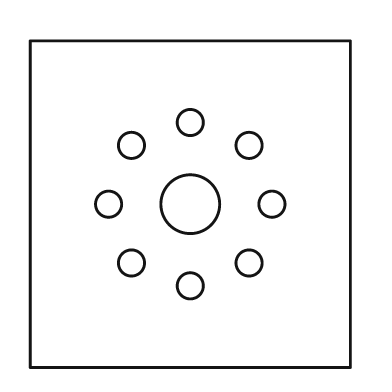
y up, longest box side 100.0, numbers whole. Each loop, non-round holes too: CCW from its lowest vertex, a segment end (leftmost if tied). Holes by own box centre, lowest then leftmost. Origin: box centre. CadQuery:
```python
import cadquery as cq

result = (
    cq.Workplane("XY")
    .moveTo(-49.0, -50.0)
    .lineTo(49.0, -50.0)
    .lineTo(49.0, 50.0)
    .lineTo(-49.0, 50.0)
    .close()
    .moveTo(0.0, -25.0)
    .circle(4.0)
    .moveTo(-18.0, -18.0)
    .circle(4.0)
    .moveTo(18.0, -18.0)
    .circle(4.0)
    .moveTo(-25.0, 0.0)
    .circle(4.0)
    .moveTo(0.0, 0.0)
    .circle(9.0)
    .moveTo(25.0, 0.0)
    .circle(4.0)
    .moveTo(-18.0, 18.0)
    .circle(4.0)
    .moveTo(18.0, 18.0)
    .circle(4.0)
    .moveTo(0.0, 25.0)
    .circle(4.0)
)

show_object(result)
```